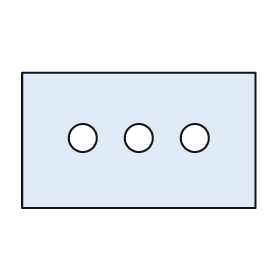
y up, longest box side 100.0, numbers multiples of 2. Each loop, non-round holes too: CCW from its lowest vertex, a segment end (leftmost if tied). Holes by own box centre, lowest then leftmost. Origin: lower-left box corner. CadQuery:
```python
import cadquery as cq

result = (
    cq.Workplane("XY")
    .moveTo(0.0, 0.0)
    .lineTo(100.0, 0.0)
    .lineTo(100.0, 58.0)
    .lineTo(0.0, 58.0)
    .close()
    .moveTo(26.0, 30.0)
    .circle(6.0)
    .moveTo(50.0, 30.0)
    .circle(6.0)
    .moveTo(74.0, 30.0)
    .circle(6.0)
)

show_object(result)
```